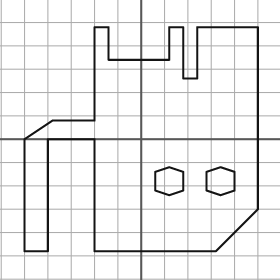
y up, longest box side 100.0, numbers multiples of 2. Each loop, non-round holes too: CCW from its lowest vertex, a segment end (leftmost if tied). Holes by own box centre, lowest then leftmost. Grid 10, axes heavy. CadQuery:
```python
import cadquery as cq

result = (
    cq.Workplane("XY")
    .moveTo(-50.0, -48.0)
    .lineTo(-40.0, -48.0)
    .lineTo(-40.0, 0.0)
    .lineTo(-20.0, 0.0)
    .lineTo(-20.0, -48.0)
    .lineTo(32.0, -48.0)
    .lineTo(50.0, -30.0)
    .lineTo(50.0, 48.0)
    .lineTo(24.0, 48.0)
    .lineTo(24.0, 26.0)
    .lineTo(18.0, 26.0)
    .lineTo(18.0, 48.0)
    .lineTo(12.0, 48.0)
    .lineTo(12.0, 34.0)
    .lineTo(-14.0, 34.0)
    .lineTo(-14.0, 48.0)
    .lineTo(-20.0, 48.0)
    .lineTo(-20.0, 8.0)
    .lineTo(-38.0, 8.0)
    .lineTo(-50.0, 0.0)
    .close()
    .moveTo(12.0, -24.0)
    .lineTo(18.0, -22.0)
    .lineTo(18.0, -14.0)
    .lineTo(12.0, -12.0)
    .lineTo(6.0, -14.0)
    .lineTo(6.0, -22.0)
    .close()
    .moveTo(34.0, -24.0)
    .lineTo(40.0, -22.0)
    .lineTo(40.0, -14.0)
    .lineTo(34.0, -12.0)
    .lineTo(28.0, -14.0)
    .lineTo(28.0, -22.0)
    .close()
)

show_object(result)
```